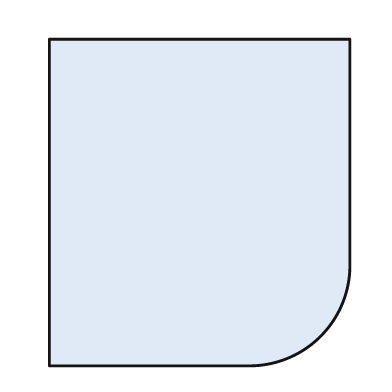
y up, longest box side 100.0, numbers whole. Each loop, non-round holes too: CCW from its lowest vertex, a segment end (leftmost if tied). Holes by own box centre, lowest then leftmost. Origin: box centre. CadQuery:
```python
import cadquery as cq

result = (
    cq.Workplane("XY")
    .moveTo(-46.0, -50.0)
    .lineTo(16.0, -50.0)
    .threePointArc((37.0, -41.0), (46.0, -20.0))
    .lineTo(46.0, 50.0)
    .lineTo(-46.0, 50.0)
    .close()
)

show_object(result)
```